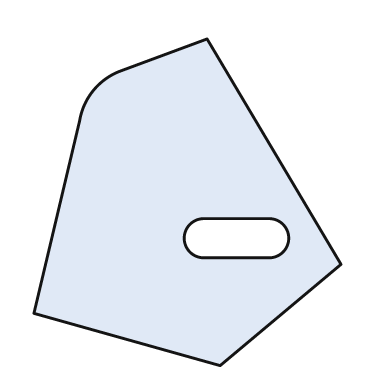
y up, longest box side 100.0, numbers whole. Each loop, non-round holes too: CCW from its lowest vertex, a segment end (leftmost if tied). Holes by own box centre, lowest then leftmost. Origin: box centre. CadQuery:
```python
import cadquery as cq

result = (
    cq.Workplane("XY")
    .moveTo(10.0, -50.0)
    .lineTo(47.0, -19.0)
    .lineTo(6.0, 50.0)
    .lineTo(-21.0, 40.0)
    .threePointArc((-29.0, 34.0), (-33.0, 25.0))
    .lineTo(-47.0, -34.0)
    .close()
    .moveTo(5.0, -17.0)
    .lineTo(25.0, -17.0)
    .threePointArc((31.0, -11.0), (25.0, -5.0))
    .lineTo(5.0, -5.0)
    .threePointArc((-1.0, -11.0), (5.0, -17.0))
    .close()
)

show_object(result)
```